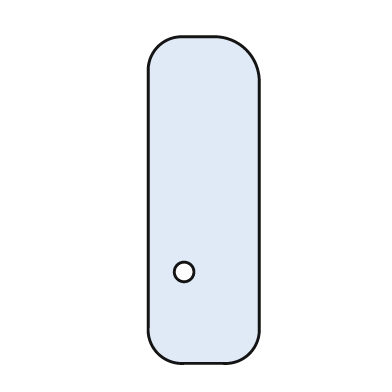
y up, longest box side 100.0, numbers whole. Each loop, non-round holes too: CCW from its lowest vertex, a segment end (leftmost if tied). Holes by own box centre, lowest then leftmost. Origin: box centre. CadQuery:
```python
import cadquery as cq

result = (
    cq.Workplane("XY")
    .moveTo(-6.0, -50.0)
    .lineTo(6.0, -50.0)
    .threePointArc((14.0, -47.0), (17.0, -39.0))
    .lineTo(17.0, 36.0)
    .threePointArc((13.0, 46.0), (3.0, 50.0))
    .lineTo(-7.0, 50.0)
    .threePointArc((-14.0, 47.0), (-17.0, 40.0))
    .lineTo(-17.0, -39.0)
    .threePointArc((-14.0, -47.0), (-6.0, -50.0))
    .close()
    .moveTo(-6.0, -22.0)
    .circle(3.0)
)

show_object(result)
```